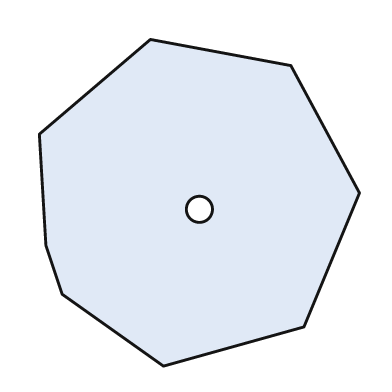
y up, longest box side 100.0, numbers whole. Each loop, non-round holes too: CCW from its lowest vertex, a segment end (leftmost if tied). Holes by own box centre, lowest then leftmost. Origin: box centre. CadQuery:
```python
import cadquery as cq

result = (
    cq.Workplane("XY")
    .moveTo(-11.0, -50.0)
    .lineTo(32.0, -38.0)
    .lineTo(49.0, 3.0)
    .lineTo(28.0, 42.0)
    .lineTo(-15.0, 50.0)
    .lineTo(-49.0, 21.0)
    .lineTo(-47.0, -13.0)
    .lineTo(-42.0, -28.0)
    .close()
    .moveTo(0.0, -2.0)
    .circle(4.0)
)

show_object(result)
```